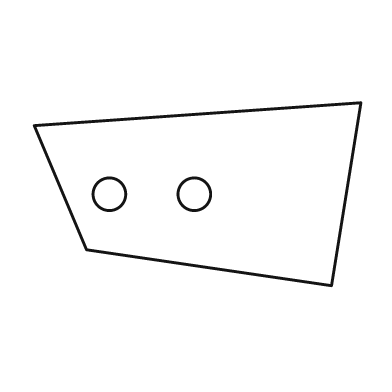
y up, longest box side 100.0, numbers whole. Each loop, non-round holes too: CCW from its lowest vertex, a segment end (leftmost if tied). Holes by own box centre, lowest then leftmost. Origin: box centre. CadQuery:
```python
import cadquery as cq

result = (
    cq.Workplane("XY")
    .moveTo(41.0, -28.0)
    .lineTo(50.0, 28.0)
    .lineTo(-50.0, 21.0)
    .lineTo(-34.0, -17.0)
    .close()
    .moveTo(-27.0, 0.0)
    .circle(5.0)
    .moveTo(-1.0, 0.0)
    .circle(5.0)
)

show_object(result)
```